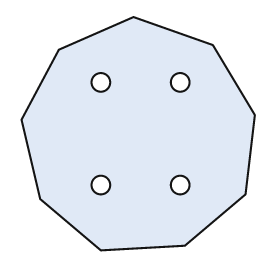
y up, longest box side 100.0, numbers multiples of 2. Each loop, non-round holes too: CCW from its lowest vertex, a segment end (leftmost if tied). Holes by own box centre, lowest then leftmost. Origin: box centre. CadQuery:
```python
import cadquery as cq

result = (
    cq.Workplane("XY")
    .moveTo(-16.0, -50.0)
    .lineTo(20.0, -48.0)
    .lineTo(46.0, -26.0)
    .lineTo(50.0, 8.0)
    .lineTo(32.0, 38.0)
    .lineTo(-2.0, 50.0)
    .lineTo(-34.0, 36.0)
    .lineTo(-50.0, 6.0)
    .lineTo(-42.0, -28.0)
    .close()
    .moveTo(-16.0, -22.0)
    .circle(4.0)
    .moveTo(18.0, -22.0)
    .circle(4.0)
    .moveTo(-16.0, 22.0)
    .circle(4.0)
    .moveTo(18.0, 22.0)
    .circle(4.0)
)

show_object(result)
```